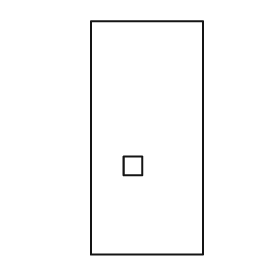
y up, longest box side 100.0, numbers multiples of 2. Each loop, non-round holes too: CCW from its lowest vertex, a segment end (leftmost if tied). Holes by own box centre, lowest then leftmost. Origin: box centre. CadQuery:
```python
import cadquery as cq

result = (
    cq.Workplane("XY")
    .moveTo(-24.0, -50.0)
    .lineTo(24.0, -50.0)
    .lineTo(24.0, 50.0)
    .lineTo(-24.0, 50.0)
    .close()
    .moveTo(-10.0, -16.0)
    .lineTo(-2.0, -16.0)
    .lineTo(-2.0, -8.0)
    .lineTo(-10.0, -8.0)
    .close()
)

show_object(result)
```